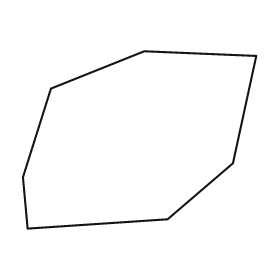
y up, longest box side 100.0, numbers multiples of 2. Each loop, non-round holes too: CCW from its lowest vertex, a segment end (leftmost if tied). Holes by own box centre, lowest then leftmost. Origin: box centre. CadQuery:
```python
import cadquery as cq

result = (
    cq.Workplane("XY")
    .moveTo(-48.0, -38.0)
    .lineTo(12.0, -34.0)
    .lineTo(40.0, -10.0)
    .lineTo(50.0, 36.0)
    .lineTo(2.0, 38.0)
    .lineTo(-38.0, 22.0)
    .lineTo(-50.0, -16.0)
    .close()
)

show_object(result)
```